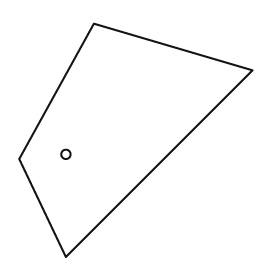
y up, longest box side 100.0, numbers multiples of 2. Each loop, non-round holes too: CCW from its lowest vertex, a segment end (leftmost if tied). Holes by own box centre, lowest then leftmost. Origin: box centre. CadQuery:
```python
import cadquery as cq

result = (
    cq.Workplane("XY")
    .moveTo(-30.0, -50.0)
    .lineTo(50.0, 30.0)
    .lineTo(-18.0, 50.0)
    .lineTo(-50.0, -8.0)
    .close()
    .moveTo(-30.0, -6.0)
    .circle(2.0)
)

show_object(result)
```